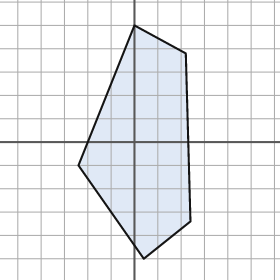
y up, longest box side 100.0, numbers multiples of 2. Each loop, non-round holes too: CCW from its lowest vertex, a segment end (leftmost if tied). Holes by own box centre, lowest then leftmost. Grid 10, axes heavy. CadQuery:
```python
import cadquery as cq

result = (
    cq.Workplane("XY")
    .moveTo(4.0, -50.0)
    .lineTo(24.0, -34.0)
    .lineTo(22.0, 38.0)
    .lineTo(0.0, 50.0)
    .lineTo(-24.0, -10.0)
    .close()
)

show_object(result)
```